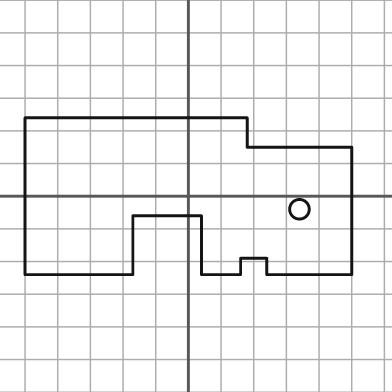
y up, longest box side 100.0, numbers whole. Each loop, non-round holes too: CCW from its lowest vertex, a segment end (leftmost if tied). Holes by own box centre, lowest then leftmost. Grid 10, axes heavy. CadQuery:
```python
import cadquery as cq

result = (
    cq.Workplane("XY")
    .moveTo(-50.0, -24.0)
    .lineTo(-17.0, -24.0)
    .lineTo(-17.0, -6.0)
    .lineTo(4.0, -6.0)
    .lineTo(4.0, -24.0)
    .lineTo(16.0, -24.0)
    .lineTo(16.0, -19.0)
    .lineTo(24.0, -19.0)
    .lineTo(24.0, -24.0)
    .lineTo(50.0, -24.0)
    .lineTo(50.0, 15.0)
    .lineTo(18.0, 15.0)
    .lineTo(18.0, 24.0)
    .lineTo(-50.0, 24.0)
    .close()
    .moveTo(34.0, -4.0)
    .circle(3.0)
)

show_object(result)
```